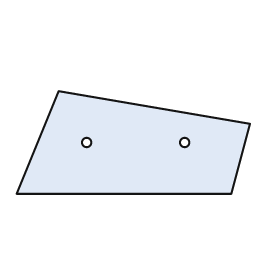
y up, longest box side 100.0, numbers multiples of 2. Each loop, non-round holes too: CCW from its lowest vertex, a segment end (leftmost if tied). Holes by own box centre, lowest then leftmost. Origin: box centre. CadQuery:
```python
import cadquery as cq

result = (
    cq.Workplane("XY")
    .moveTo(-50.0, -22.0)
    .lineTo(42.0, -22.0)
    .lineTo(50.0, 8.0)
    .lineTo(-32.0, 22.0)
    .close()
    .moveTo(-20.0, 0.0)
    .circle(2.0)
    .moveTo(22.0, 0.0)
    .circle(2.0)
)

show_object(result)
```